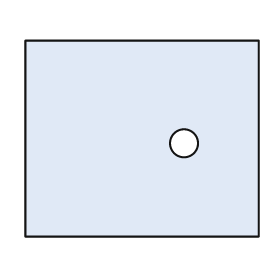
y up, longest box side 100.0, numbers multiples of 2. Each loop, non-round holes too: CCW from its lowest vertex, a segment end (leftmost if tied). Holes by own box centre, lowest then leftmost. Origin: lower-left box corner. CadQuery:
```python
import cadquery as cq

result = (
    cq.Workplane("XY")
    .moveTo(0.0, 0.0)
    .lineTo(100.0, 0.0)
    .lineTo(100.0, 84.0)
    .lineTo(0.0, 84.0)
    .close()
    .moveTo(68.0, 40.0)
    .circle(6.0)
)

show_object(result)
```